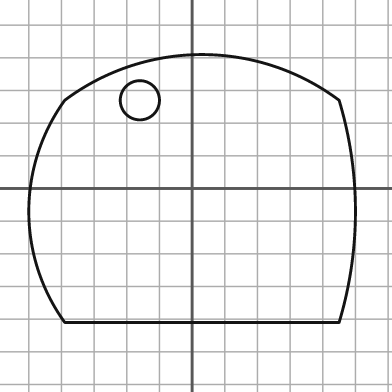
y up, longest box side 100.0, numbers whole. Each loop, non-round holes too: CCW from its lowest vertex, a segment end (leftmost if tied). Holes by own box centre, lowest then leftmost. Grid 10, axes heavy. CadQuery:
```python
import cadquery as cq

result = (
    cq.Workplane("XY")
    .moveTo(-39.0, -41.0)
    .lineTo(45.0, -41.0)
    .threePointArc((50.0, -7.0), (45.0, 27.0))
    .threePointArc((3.0, 41.0), (-39.0, 27.0))
    .threePointArc((-50.0, -7.0), (-39.0, -41.0))
    .close()
    .moveTo(-16.0, 27.0)
    .circle(6.0)
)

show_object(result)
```